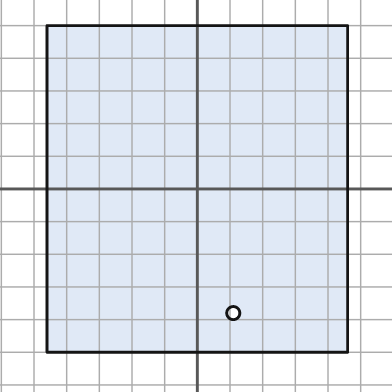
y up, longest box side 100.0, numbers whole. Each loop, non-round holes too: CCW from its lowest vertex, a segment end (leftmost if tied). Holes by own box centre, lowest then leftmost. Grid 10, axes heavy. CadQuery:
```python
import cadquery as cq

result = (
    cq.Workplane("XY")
    .moveTo(-46.0, -50.0)
    .lineTo(46.0, -50.0)
    .lineTo(46.0, 50.0)
    .lineTo(-46.0, 50.0)
    .close()
    .moveTo(11.0, -38.0)
    .circle(2.0)
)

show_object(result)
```